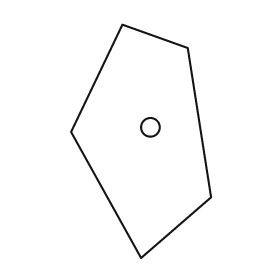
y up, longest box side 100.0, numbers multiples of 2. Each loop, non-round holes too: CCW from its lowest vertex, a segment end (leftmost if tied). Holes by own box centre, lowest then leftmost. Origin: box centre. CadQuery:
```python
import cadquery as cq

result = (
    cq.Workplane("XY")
    .moveTo(0.0, -50.0)
    .lineTo(30.0, -24.0)
    .lineTo(20.0, 40.0)
    .lineTo(-8.0, 50.0)
    .lineTo(-30.0, 4.0)
    .close()
    .moveTo(4.0, 6.0)
    .circle(4.0)
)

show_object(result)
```